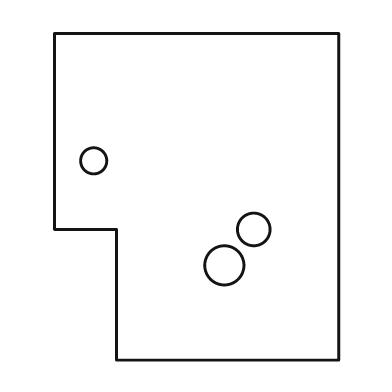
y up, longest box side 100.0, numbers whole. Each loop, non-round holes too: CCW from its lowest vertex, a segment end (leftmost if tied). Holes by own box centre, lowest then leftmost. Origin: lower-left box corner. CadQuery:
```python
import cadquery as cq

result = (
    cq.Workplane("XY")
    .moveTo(19.0, 0.0)
    .lineTo(87.0, 0.0)
    .lineTo(87.0, 100.0)
    .lineTo(0.0, 100.0)
    .lineTo(0.0, 40.0)
    .lineTo(19.0, 40.0)
    .close()
    .moveTo(52.0, 29.0)
    .circle(6.0)
    .moveTo(61.0, 40.0)
    .circle(5.0)
    .moveTo(12.0, 61.0)
    .circle(4.0)
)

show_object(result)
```